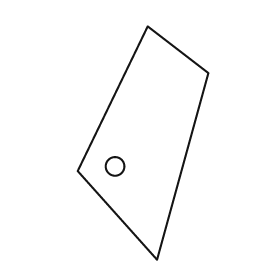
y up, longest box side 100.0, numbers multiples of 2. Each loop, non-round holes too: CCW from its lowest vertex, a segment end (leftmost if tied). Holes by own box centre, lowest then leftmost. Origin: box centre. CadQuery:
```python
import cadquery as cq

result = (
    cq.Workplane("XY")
    .moveTo(6.0, -50.0)
    .lineTo(28.0, 30.0)
    .lineTo(2.0, 50.0)
    .lineTo(-28.0, -12.0)
    .close()
    .moveTo(-12.0, -10.0)
    .circle(4.0)
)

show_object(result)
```